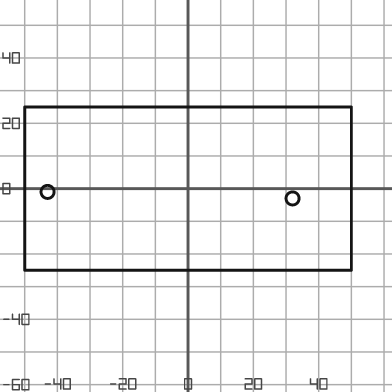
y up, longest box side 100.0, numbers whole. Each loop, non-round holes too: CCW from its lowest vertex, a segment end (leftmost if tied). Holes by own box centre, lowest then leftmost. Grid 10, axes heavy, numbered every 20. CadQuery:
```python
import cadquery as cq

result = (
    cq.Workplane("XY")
    .moveTo(-50.0, -25.0)
    .lineTo(50.0, -25.0)
    .lineTo(50.0, 25.0)
    .lineTo(-50.0, 25.0)
    .close()
    .moveTo(32.0, -3.0)
    .circle(2.0)
    .moveTo(-43.0, -1.0)
    .circle(2.0)
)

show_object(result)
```